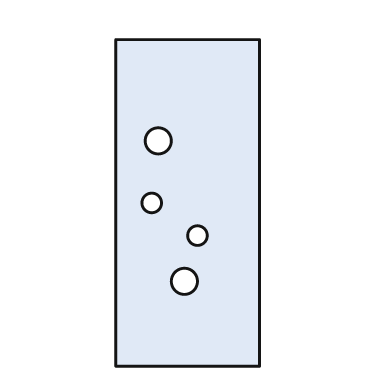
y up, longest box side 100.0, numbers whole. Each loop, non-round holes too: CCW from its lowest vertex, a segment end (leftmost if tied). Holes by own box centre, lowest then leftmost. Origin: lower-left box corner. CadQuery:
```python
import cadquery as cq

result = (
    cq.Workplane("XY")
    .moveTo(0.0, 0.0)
    .lineTo(44.0, 0.0)
    .lineTo(44.0, 100.0)
    .lineTo(0.0, 100.0)
    .close()
    .moveTo(21.0, 26.0)
    .circle(4.0)
    .moveTo(25.0, 40.0)
    .circle(3.0)
    .moveTo(11.0, 50.0)
    .circle(3.0)
    .moveTo(13.0, 69.0)
    .circle(4.0)
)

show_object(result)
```